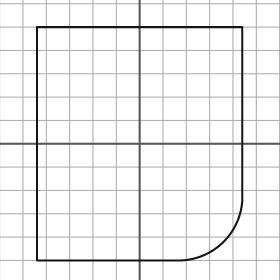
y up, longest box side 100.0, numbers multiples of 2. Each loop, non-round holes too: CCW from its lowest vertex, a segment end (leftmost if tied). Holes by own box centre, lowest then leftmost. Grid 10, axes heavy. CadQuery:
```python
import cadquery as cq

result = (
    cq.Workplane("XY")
    .moveTo(-44.0, -50.0)
    .lineTo(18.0, -50.0)
    .threePointArc((36.0, -42.0), (44.0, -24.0))
    .lineTo(44.0, 50.0)
    .lineTo(-44.0, 50.0)
    .close()
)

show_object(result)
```